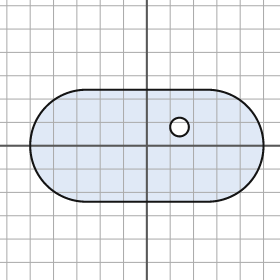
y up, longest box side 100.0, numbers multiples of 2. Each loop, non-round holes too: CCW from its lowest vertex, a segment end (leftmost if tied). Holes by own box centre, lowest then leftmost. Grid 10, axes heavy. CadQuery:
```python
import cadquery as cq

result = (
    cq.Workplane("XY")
    .moveTo(-26.0, -24.0)
    .lineTo(26.0, -24.0)
    .threePointArc((50.0, 0.0), (26.0, 24.0))
    .lineTo(-26.0, 24.0)
    .threePointArc((-50.0, 0.0), (-26.0, -24.0))
    .close()
    .moveTo(14.0, 8.0)
    .circle(4.0)
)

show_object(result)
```